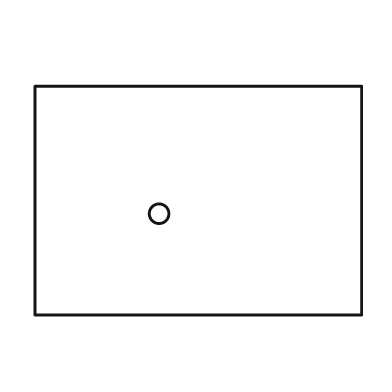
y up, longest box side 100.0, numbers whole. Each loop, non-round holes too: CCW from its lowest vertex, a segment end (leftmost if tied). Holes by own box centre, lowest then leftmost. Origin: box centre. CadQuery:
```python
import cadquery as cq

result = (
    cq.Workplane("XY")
    .moveTo(-50.0, -35.0)
    .lineTo(50.0, -35.0)
    .lineTo(50.0, 35.0)
    .lineTo(-50.0, 35.0)
    .close()
    .moveTo(-12.0, -4.0)
    .circle(3.0)
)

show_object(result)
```